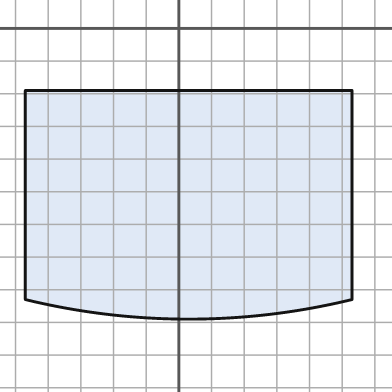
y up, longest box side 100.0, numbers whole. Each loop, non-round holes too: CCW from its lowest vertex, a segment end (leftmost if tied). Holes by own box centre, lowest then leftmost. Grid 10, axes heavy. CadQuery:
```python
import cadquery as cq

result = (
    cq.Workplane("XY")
    .moveTo(-47.0, -83.0)
    .threePointArc((3.0, -89.0), (53.0, -83.0))
    .lineTo(53.0, -19.0)
    .lineTo(-47.0, -19.0)
    .close()
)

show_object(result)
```